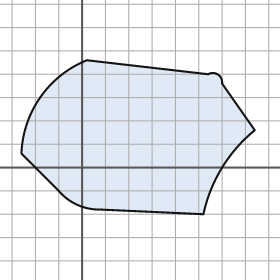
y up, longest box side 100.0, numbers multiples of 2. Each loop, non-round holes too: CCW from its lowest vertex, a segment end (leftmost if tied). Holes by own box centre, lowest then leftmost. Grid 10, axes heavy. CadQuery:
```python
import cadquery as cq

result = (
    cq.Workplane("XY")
    .moveTo(52.0, -20.0)
    .threePointArc((60.0, 0.0), (74.0, 16.0))
    .lineTo(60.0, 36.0)
    .threePointArc((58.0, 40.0), (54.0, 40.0))
    .lineTo(2.0, 46.0)
    .threePointArc((-18.0, 30.0), (-26.0, 6.0))
    .lineTo(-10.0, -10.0)
    .threePointArc((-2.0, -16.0), (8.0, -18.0))
    .close()
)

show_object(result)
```